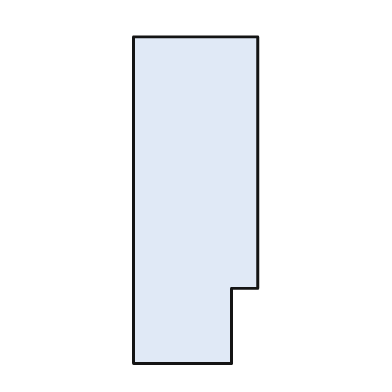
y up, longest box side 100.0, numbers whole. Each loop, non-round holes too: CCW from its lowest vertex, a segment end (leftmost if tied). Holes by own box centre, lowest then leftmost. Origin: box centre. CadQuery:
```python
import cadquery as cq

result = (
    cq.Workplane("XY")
    .moveTo(-19.0, -50.0)
    .lineTo(11.0, -50.0)
    .lineTo(11.0, -27.0)
    .lineTo(19.0, -27.0)
    .lineTo(19.0, 50.0)
    .lineTo(-19.0, 50.0)
    .close()
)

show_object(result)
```